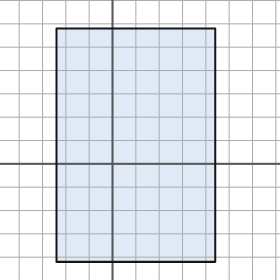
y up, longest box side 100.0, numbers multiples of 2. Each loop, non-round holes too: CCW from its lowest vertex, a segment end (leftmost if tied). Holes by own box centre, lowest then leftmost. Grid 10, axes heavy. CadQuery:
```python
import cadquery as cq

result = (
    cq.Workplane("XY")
    .moveTo(-24.0, -42.0)
    .lineTo(44.0, -42.0)
    .lineTo(44.0, 58.0)
    .lineTo(-24.0, 58.0)
    .close()
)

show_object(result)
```